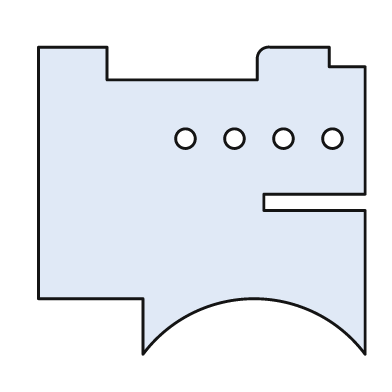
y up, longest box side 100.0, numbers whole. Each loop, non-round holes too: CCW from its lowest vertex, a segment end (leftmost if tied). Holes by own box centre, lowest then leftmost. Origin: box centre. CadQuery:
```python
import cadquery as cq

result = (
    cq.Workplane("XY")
    .moveTo(-18.0, -47.0)
    .threePointArc((16.0, -30.0), (50.0, -47.0))
    .lineTo(50.0, -3.0)
    .lineTo(19.0, -3.0)
    .lineTo(19.0, 2.0)
    .lineTo(50.0, 2.0)
    .lineTo(50.0, 41.0)
    .lineTo(39.0, 41.0)
    .lineTo(39.0, 47.0)
    .lineTo(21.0, 47.0)
    .threePointArc((18.0, 46.0), (17.0, 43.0))
    .lineTo(17.0, 37.0)
    .lineTo(-29.0, 37.0)
    .lineTo(-29.0, 47.0)
    .lineTo(-50.0, 47.0)
    .lineTo(-50.0, -30.0)
    .lineTo(-18.0, -30.0)
    .close()
    .moveTo(-5.0, 19.0)
    .circle(3.0)
    .moveTo(10.0, 19.0)
    .circle(3.0)
    .moveTo(25.0, 19.0)
    .circle(3.0)
    .moveTo(40.0, 19.0)
    .circle(3.0)
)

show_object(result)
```